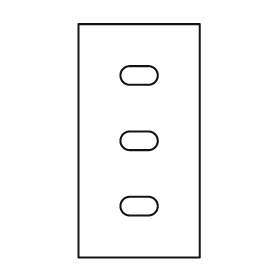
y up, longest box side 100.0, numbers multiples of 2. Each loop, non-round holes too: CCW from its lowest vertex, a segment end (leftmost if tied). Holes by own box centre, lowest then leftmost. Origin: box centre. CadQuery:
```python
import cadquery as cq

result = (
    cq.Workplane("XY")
    .moveTo(-26.0, -50.0)
    .lineTo(26.0, -50.0)
    .lineTo(26.0, 50.0)
    .lineTo(-26.0, 50.0)
    .close()
    .moveTo(-4.0, -32.0)
    .lineTo(4.0, -32.0)
    .threePointArc((8.0, -28.0), (4.0, -24.0))
    .lineTo(-4.0, -24.0)
    .threePointArc((-8.0, -28.0), (-4.0, -32.0))
    .close()
    .moveTo(-4.0, -4.0)
    .lineTo(4.0, -4.0)
    .threePointArc((8.0, 0.0), (4.0, 4.0))
    .lineTo(-4.0, 4.0)
    .threePointArc((-8.0, 0.0), (-4.0, -4.0))
    .close()
    .moveTo(-4.0, 24.0)
    .lineTo(4.0, 24.0)
    .threePointArc((8.0, 28.0), (4.0, 32.0))
    .lineTo(-4.0, 32.0)
    .threePointArc((-8.0, 28.0), (-4.0, 24.0))
    .close()
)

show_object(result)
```